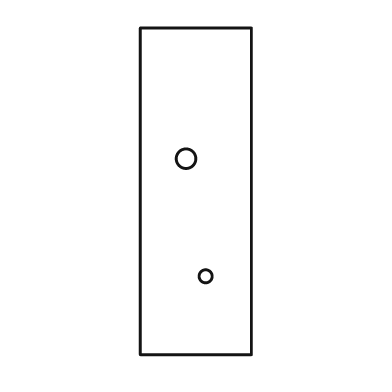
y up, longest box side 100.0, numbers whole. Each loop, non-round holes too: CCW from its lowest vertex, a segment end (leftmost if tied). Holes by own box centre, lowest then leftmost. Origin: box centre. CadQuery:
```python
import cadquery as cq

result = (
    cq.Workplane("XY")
    .moveTo(-17.0, -50.0)
    .lineTo(17.0, -50.0)
    .lineTo(17.0, 50.0)
    .lineTo(-17.0, 50.0)
    .close()
    .moveTo(3.0, -26.0)
    .circle(2.0)
    .moveTo(-3.0, 10.0)
    .circle(3.0)
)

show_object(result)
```